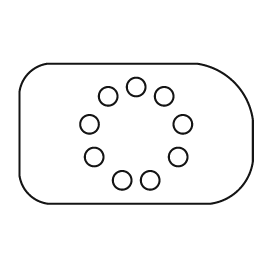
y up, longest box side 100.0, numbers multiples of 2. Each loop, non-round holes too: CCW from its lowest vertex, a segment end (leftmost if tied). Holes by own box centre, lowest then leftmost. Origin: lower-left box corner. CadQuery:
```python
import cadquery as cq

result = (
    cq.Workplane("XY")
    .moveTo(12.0, 0.0)
    .lineTo(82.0, 0.0)
    .threePointArc((94.0, 6.0), (100.0, 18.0))
    .lineTo(100.0, 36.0)
    .threePointArc((92.0, 52.0), (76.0, 60.0))
    .lineTo(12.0, 60.0)
    .threePointArc((4.0, 56.0), (0.0, 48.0))
    .lineTo(0.0, 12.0)
    .threePointArc((4.0, 4.0), (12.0, 0.0))
    .close()
    .moveTo(44.0, 10.0)
    .circle(4.0)
    .moveTo(56.0, 10.0)
    .circle(4.0)
    .moveTo(32.0, 20.0)
    .circle(4.0)
    .moveTo(68.0, 20.0)
    .circle(4.0)
    .moveTo(30.0, 34.0)
    .circle(4.0)
    .moveTo(70.0, 34.0)
    .circle(4.0)
    .moveTo(38.0, 46.0)
    .circle(4.0)
    .moveTo(62.0, 46.0)
    .circle(4.0)
    .moveTo(50.0, 50.0)
    .circle(4.0)
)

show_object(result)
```